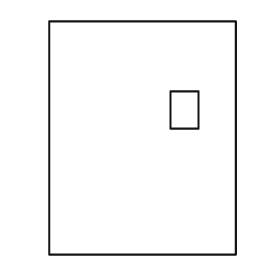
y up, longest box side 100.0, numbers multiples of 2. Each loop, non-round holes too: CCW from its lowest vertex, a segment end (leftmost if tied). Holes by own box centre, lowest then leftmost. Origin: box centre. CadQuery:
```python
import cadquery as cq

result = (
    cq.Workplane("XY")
    .moveTo(-40.0, -50.0)
    .lineTo(40.0, -50.0)
    .lineTo(40.0, 50.0)
    .lineTo(-40.0, 50.0)
    .close()
    .moveTo(12.0, 4.0)
    .lineTo(24.0, 4.0)
    .lineTo(24.0, 20.0)
    .lineTo(12.0, 20.0)
    .close()
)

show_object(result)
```